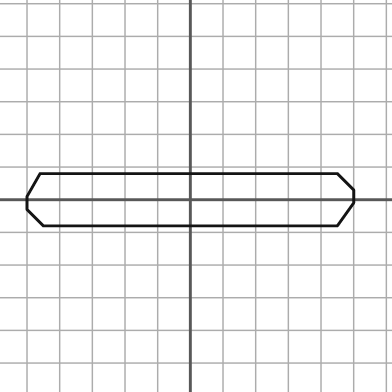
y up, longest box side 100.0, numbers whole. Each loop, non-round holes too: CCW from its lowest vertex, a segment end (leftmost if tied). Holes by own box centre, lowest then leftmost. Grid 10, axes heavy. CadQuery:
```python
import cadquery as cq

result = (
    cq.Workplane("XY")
    .moveTo(-45.0, -8.0)
    .lineTo(45.0, -8.0)
    .lineTo(50.0, -1.0)
    .lineTo(50.0, 3.0)
    .lineTo(45.0, 8.0)
    .lineTo(-46.0, 8.0)
    .lineTo(-50.0, 1.0)
    .lineTo(-50.0, -3.0)
    .close()
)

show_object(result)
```